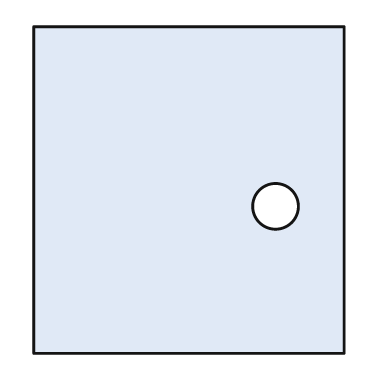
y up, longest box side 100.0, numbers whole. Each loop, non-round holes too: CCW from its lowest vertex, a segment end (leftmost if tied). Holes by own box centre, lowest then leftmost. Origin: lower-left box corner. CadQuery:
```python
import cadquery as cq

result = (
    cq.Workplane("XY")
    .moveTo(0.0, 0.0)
    .lineTo(95.0, 0.0)
    .lineTo(95.0, 100.0)
    .lineTo(0.0, 100.0)
    .close()
    .moveTo(74.0, 45.0)
    .circle(7.0)
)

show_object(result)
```